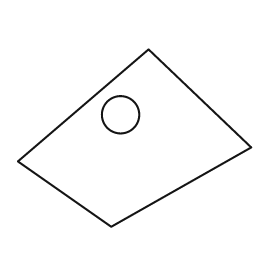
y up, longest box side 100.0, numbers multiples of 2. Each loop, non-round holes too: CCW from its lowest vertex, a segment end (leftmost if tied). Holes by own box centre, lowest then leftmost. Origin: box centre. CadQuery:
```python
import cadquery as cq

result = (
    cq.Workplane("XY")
    .moveTo(-10.0, -38.0)
    .lineTo(50.0, -4.0)
    .lineTo(6.0, 38.0)
    .lineTo(-50.0, -10.0)
    .close()
    .moveTo(-6.0, 10.0)
    .circle(8.0)
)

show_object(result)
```